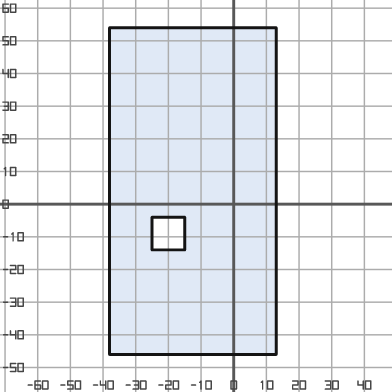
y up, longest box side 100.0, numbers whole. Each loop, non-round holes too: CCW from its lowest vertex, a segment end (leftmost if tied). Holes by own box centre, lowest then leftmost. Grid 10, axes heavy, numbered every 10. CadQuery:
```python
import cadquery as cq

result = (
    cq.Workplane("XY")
    .moveTo(-38.0, -46.0)
    .lineTo(13.0, -46.0)
    .lineTo(13.0, 54.0)
    .lineTo(-38.0, 54.0)
    .close()
    .moveTo(-25.0, -14.0)
    .lineTo(-15.0, -14.0)
    .lineTo(-15.0, -4.0)
    .lineTo(-25.0, -4.0)
    .close()
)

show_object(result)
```